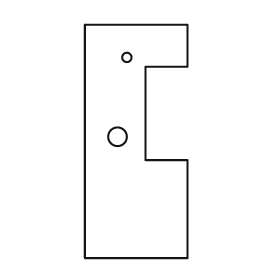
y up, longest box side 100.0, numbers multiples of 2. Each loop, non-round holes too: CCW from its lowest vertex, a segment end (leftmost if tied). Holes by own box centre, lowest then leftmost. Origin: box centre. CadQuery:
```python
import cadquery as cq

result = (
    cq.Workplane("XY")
    .moveTo(-22.0, -50.0)
    .lineTo(22.0, -50.0)
    .lineTo(22.0, -8.0)
    .lineTo(4.0, -8.0)
    .lineTo(4.0, 32.0)
    .lineTo(22.0, 32.0)
    .lineTo(22.0, 50.0)
    .lineTo(-22.0, 50.0)
    .close()
    .moveTo(-8.0, 2.0)
    .circle(4.0)
    .moveTo(-4.0, 36.0)
    .circle(2.0)
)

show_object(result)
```